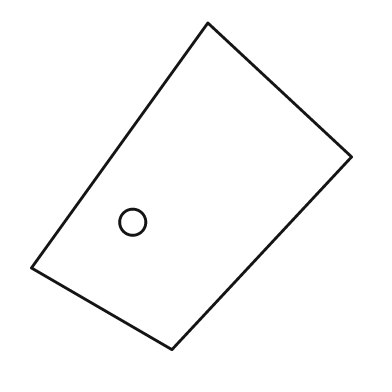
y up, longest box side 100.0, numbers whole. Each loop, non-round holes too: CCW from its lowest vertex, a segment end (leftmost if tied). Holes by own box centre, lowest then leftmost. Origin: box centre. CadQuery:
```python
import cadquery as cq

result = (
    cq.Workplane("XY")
    .moveTo(-6.0, -50.0)
    .lineTo(49.0, 9.0)
    .lineTo(5.0, 50.0)
    .lineTo(-49.0, -25.0)
    .close()
    .moveTo(-18.0, -11.0)
    .circle(4.0)
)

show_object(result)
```